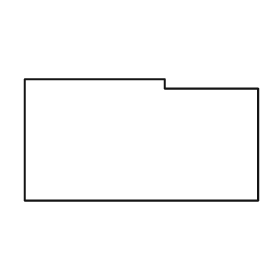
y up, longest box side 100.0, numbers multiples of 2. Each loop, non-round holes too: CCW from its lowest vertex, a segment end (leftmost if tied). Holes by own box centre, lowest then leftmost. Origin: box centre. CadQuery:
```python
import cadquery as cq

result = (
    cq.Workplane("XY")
    .moveTo(-50.0, -26.0)
    .lineTo(50.0, -26.0)
    .lineTo(50.0, 22.0)
    .lineTo(10.0, 22.0)
    .lineTo(10.0, 26.0)
    .lineTo(-50.0, 26.0)
    .close()
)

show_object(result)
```